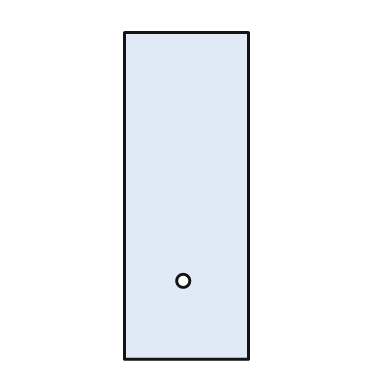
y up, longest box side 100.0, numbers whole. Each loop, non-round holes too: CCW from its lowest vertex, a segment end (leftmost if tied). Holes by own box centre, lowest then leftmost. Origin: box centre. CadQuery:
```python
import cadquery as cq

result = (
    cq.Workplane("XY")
    .moveTo(-19.0, -50.0)
    .lineTo(19.0, -50.0)
    .lineTo(19.0, 50.0)
    .lineTo(-19.0, 50.0)
    .close()
    .moveTo(-1.0, -26.0)
    .circle(2.0)
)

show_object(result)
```